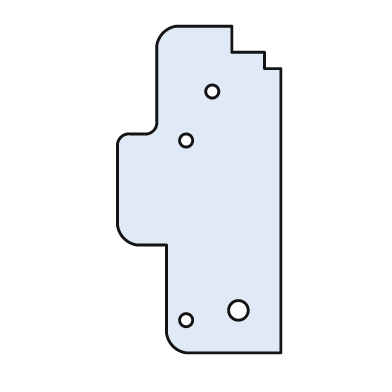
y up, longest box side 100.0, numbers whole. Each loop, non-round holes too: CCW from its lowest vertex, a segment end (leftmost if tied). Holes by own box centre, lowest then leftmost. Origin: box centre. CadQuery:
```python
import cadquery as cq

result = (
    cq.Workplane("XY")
    .moveTo(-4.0, -50.0)
    .lineTo(25.0, -50.0)
    .lineTo(25.0, 37.0)
    .lineTo(20.0, 37.0)
    .lineTo(20.0, 42.0)
    .lineTo(10.0, 42.0)
    .lineTo(10.0, 50.0)
    .lineTo(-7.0, 50.0)
    .threePointArc((-11.0, 48.0), (-13.0, 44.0))
    .lineTo(-13.0, 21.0)
    .threePointArc((-14.0, 18.0), (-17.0, 17.0))
    .lineTo(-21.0, 17.0)
    .threePointArc((-24.0, 16.0), (-25.0, 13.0))
    .lineTo(-25.0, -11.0)
    .threePointArc((-23.0, -15.0), (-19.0, -17.0))
    .lineTo(-10.0, -17.0)
    .lineTo(-10.0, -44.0)
    .threePointArc((-8.0, -48.0), (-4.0, -50.0))
    .close()
    .moveTo(-4.0, -40.0)
    .circle(2.0)
    .moveTo(12.0, -37.0)
    .circle(3.0)
    .moveTo(-4.0, 15.0)
    .circle(2.0)
    .moveTo(4.0, 30.0)
    .circle(2.0)
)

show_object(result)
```